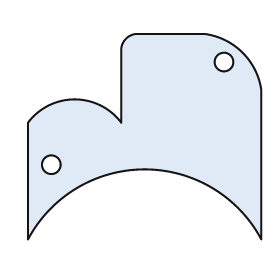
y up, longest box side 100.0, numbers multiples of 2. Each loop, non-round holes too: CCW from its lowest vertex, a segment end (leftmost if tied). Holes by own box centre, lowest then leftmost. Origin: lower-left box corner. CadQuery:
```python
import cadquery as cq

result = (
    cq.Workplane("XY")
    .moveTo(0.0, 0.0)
    .threePointArc((50.0, 30.0), (100.0, 0.0))
    .lineTo(100.0, 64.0)
    .threePointArc((92.0, 80.0), (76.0, 88.0))
    .lineTo(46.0, 88.0)
    .threePointArc((42.0, 86.0), (40.0, 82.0))
    .lineTo(40.0, 50.0)
    .threePointArc((20.0, 60.0), (0.0, 50.0))
    .close()
    .moveTo(10.0, 32.0)
    .circle(4.0)
    .moveTo(84.0, 76.0)
    .circle(4.0)
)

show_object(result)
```